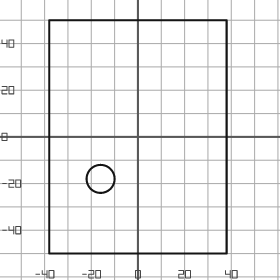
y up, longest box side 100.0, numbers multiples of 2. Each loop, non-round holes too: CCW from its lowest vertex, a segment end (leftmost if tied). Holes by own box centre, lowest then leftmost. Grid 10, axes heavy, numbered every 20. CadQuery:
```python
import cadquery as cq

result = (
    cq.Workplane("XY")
    .moveTo(-38.0, -50.0)
    .lineTo(38.0, -50.0)
    .lineTo(38.0, 50.0)
    .lineTo(-38.0, 50.0)
    .close()
    .moveTo(-16.0, -18.0)
    .circle(6.0)
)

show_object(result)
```